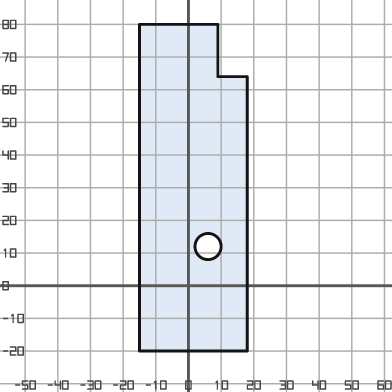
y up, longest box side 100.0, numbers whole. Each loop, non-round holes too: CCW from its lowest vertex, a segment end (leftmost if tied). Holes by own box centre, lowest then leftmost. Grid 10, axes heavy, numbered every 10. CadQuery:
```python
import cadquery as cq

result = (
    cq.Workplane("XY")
    .moveTo(-15.0, -20.0)
    .lineTo(18.0, -20.0)
    .lineTo(18.0, 64.0)
    .lineTo(9.0, 64.0)
    .lineTo(9.0, 80.0)
    .lineTo(-15.0, 80.0)
    .close()
    .moveTo(6.0, 12.0)
    .circle(4.0)
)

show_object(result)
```